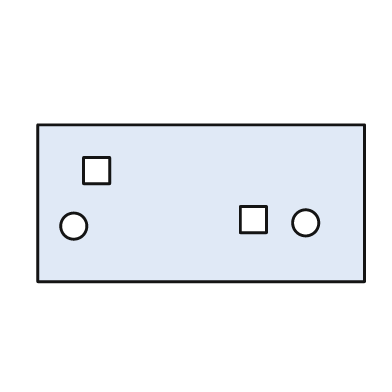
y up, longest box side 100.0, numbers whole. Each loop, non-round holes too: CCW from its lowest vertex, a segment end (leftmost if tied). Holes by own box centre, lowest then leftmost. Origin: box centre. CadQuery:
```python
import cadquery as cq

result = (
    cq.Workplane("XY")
    .moveTo(-50.0, -24.0)
    .lineTo(50.0, -24.0)
    .lineTo(50.0, 24.0)
    .lineTo(-50.0, 24.0)
    .close()
    .moveTo(-39.0, -7.0)
    .circle(4.0)
    .moveTo(32.0, -6.0)
    .circle(4.0)
    .moveTo(12.0, -9.0)
    .lineTo(20.0, -9.0)
    .lineTo(20.0, -1.0)
    .lineTo(12.0, -1.0)
    .close()
    .moveTo(-36.0, 6.0)
    .lineTo(-28.0, 6.0)
    .lineTo(-28.0, 14.0)
    .lineTo(-36.0, 14.0)
    .close()
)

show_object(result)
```